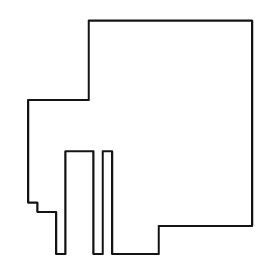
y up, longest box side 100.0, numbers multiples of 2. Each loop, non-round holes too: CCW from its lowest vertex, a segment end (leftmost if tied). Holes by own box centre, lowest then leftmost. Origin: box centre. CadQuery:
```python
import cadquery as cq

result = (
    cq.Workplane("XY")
    .moveTo(-36.0, -50.0)
    .lineTo(-32.0, -50.0)
    .lineTo(-32.0, -6.0)
    .lineTo(-20.0, -6.0)
    .lineTo(-20.0, -50.0)
    .lineTo(-16.0, -50.0)
    .lineTo(-16.0, -6.0)
    .lineTo(-12.0, -6.0)
    .lineTo(-12.0, -50.0)
    .lineTo(8.0, -50.0)
    .lineTo(8.0, -38.0)
    .lineTo(48.0, -38.0)
    .lineTo(48.0, 50.0)
    .lineTo(-22.0, 50.0)
    .lineTo(-22.0, 16.0)
    .lineTo(-48.0, 16.0)
    .lineTo(-48.0, -28.0)
    .lineTo(-44.0, -28.0)
    .lineTo(-44.0, -32.0)
    .lineTo(-36.0, -32.0)
    .close()
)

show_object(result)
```